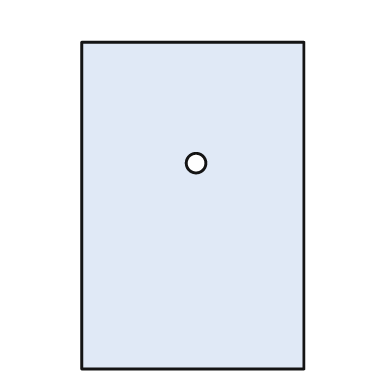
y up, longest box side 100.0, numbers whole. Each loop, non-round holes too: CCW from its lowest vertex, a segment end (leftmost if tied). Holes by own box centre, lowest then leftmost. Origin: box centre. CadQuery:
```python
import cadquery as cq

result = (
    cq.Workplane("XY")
    .moveTo(-34.0, -50.0)
    .lineTo(34.0, -50.0)
    .lineTo(34.0, 50.0)
    .lineTo(-34.0, 50.0)
    .close()
    .moveTo(1.0, 13.0)
    .circle(3.0)
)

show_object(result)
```